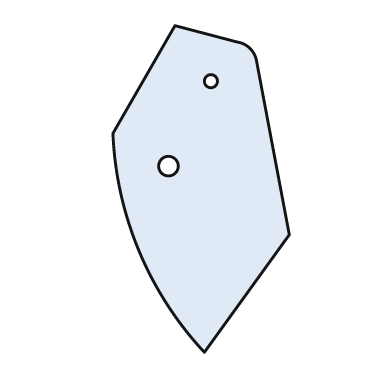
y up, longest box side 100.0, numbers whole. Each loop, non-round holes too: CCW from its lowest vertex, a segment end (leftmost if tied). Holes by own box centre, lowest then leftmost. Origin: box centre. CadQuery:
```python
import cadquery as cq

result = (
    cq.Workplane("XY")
    .moveTo(1.0, -50.0)
    .lineTo(27.0, -14.0)
    .lineTo(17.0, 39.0)
    .threePointArc((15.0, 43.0), (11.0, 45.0))
    .lineTo(-8.0, 50.0)
    .lineTo(-27.0, 17.0)
    .threePointArc((-19.0, -19.0), (1.0, -50.0))
    .close()
    .moveTo(-10.0, 7.0)
    .circle(3.0)
    .moveTo(3.0, 33.0)
    .circle(2.0)
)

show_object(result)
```